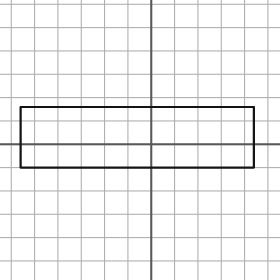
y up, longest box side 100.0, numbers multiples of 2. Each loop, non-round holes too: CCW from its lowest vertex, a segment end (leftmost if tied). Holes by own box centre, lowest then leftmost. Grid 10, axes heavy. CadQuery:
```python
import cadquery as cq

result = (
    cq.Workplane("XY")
    .moveTo(-56.0, -10.0)
    .lineTo(44.0, -10.0)
    .lineTo(44.0, 16.0)
    .lineTo(-56.0, 16.0)
    .close()
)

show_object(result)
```